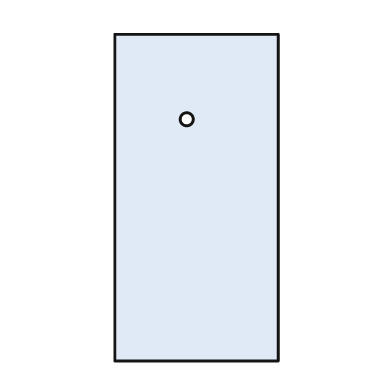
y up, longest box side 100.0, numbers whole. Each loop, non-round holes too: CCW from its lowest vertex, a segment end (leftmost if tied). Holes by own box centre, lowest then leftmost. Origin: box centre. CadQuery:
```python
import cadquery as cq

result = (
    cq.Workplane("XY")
    .moveTo(-25.0, -50.0)
    .lineTo(25.0, -50.0)
    .lineTo(25.0, 50.0)
    .lineTo(-25.0, 50.0)
    .close()
    .moveTo(-3.0, 24.0)
    .circle(2.0)
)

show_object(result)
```